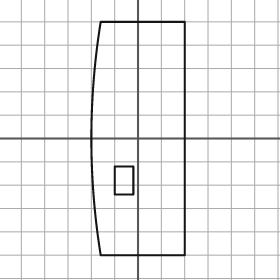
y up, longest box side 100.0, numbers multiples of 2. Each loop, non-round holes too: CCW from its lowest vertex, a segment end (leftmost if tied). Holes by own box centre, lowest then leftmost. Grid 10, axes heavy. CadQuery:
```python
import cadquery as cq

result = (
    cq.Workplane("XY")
    .moveTo(-16.0, -50.0)
    .lineTo(20.0, -50.0)
    .lineTo(20.0, 50.0)
    .lineTo(-16.0, 50.0)
    .threePointArc((-20.0, 0.0), (-16.0, -50.0))
    .close()
    .moveTo(-10.0, -24.0)
    .lineTo(-2.0, -24.0)
    .lineTo(-2.0, -12.0)
    .lineTo(-10.0, -12.0)
    .close()
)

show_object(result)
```